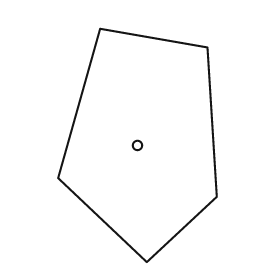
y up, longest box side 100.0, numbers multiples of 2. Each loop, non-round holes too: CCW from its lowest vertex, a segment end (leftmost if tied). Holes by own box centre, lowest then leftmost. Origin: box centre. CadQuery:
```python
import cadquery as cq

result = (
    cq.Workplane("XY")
    .moveTo(4.0, -50.0)
    .lineTo(34.0, -22.0)
    .lineTo(30.0, 42.0)
    .lineTo(-16.0, 50.0)
    .lineTo(-34.0, -14.0)
    .close()
    .moveTo(0.0, 0.0)
    .circle(2.0)
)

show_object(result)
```